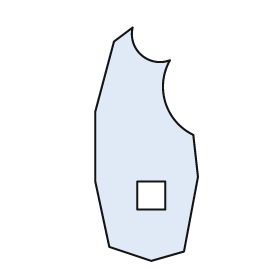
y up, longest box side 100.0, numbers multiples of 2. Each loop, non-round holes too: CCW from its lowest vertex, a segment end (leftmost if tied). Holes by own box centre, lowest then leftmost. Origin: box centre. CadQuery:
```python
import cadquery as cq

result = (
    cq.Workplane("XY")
    .moveTo(2.0, -50.0)
    .lineTo(16.0, -46.0)
    .lineTo(22.0, -14.0)
    .lineTo(20.0, 4.0)
    .threePointArc((8.0, 18.0), (10.0, 36.0))
    .threePointArc((-2.0, 38.0), (-6.0, 50.0))
    .lineTo(-14.0, 44.0)
    .lineTo(-22.0, 14.0)
    .lineTo(-22.0, -16.0)
    .lineTo(-16.0, -44.0)
    .close()
    .moveTo(-4.0, -28.0)
    .lineTo(8.0, -28.0)
    .lineTo(8.0, -16.0)
    .lineTo(-4.0, -16.0)
    .close()
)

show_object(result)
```